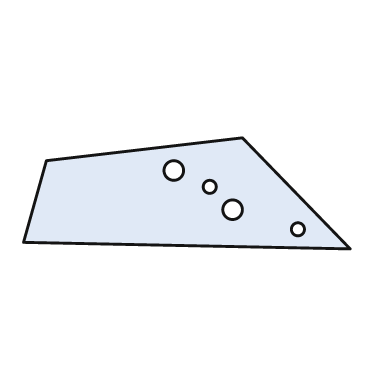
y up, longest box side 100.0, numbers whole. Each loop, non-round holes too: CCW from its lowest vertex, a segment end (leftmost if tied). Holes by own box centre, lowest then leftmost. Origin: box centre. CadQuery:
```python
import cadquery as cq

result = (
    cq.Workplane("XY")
    .moveTo(50.0, -17.0)
    .lineTo(17.0, 17.0)
    .lineTo(-43.0, 10.0)
    .lineTo(-50.0, -15.0)
    .close()
    .moveTo(34.0, -11.0)
    .circle(2.0)
    .moveTo(14.0, -5.0)
    .circle(3.0)
    .moveTo(7.0, 2.0)
    .circle(2.0)
    .moveTo(-4.0, 7.0)
    .circle(3.0)
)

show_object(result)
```